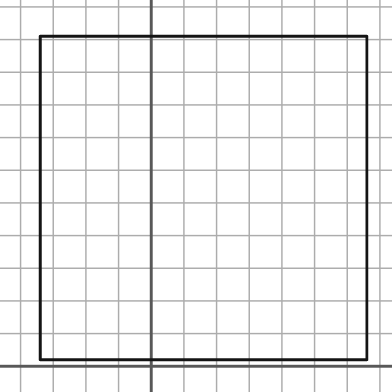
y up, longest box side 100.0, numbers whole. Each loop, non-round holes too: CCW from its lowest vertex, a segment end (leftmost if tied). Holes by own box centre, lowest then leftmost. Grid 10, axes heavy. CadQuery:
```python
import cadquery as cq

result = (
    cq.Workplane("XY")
    .moveTo(-34.0, 2.0)
    .lineTo(66.0, 2.0)
    .lineTo(66.0, 101.0)
    .lineTo(-34.0, 101.0)
    .close()
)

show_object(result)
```